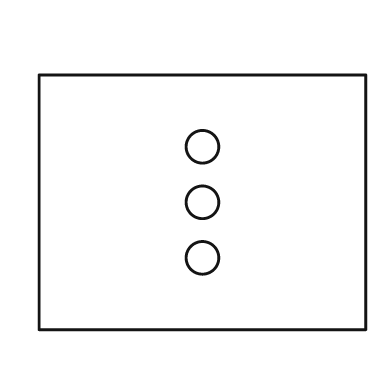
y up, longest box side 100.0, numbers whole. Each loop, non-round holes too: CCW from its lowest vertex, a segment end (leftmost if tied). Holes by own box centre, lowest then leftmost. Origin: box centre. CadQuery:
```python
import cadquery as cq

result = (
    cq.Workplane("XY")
    .moveTo(-50.0, -39.0)
    .lineTo(50.0, -39.0)
    .lineTo(50.0, 39.0)
    .lineTo(-50.0, 39.0)
    .close()
    .moveTo(0.0, -17.0)
    .circle(5.0)
    .moveTo(0.0, 0.0)
    .circle(5.0)
    .moveTo(0.0, 17.0)
    .circle(5.0)
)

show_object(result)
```